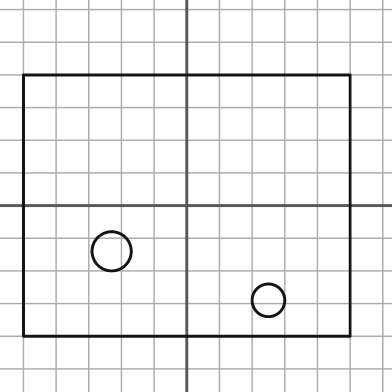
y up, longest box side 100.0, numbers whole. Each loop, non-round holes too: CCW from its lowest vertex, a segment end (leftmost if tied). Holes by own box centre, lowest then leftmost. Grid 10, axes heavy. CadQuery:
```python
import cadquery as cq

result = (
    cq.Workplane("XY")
    .moveTo(-50.0, -40.0)
    .lineTo(50.0, -40.0)
    .lineTo(50.0, 40.0)
    .lineTo(-50.0, 40.0)
    .close()
    .moveTo(25.0, -29.0)
    .circle(5.0)
    .moveTo(-23.0, -14.0)
    .circle(6.0)
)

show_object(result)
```